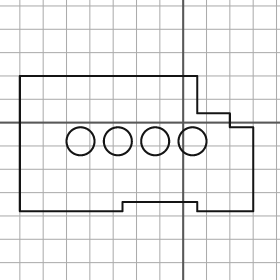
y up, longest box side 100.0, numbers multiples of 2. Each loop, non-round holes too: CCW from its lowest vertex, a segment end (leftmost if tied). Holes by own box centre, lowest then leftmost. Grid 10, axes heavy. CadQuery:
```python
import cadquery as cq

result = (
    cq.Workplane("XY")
    .moveTo(-70.0, -38.0)
    .lineTo(-26.0, -38.0)
    .lineTo(-26.0, -34.0)
    .lineTo(6.0, -34.0)
    .lineTo(6.0, -38.0)
    .lineTo(30.0, -38.0)
    .lineTo(30.0, -2.0)
    .lineTo(20.0, -2.0)
    .lineTo(20.0, 4.0)
    .lineTo(6.0, 4.0)
    .lineTo(6.0, 20.0)
    .lineTo(-70.0, 20.0)
    .close()
    .moveTo(-44.0, -8.0)
    .circle(6.0)
    .moveTo(-28.0, -8.0)
    .circle(6.0)
    .moveTo(-12.0, -8.0)
    .circle(6.0)
    .moveTo(4.0, -8.0)
    .circle(6.0)
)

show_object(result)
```